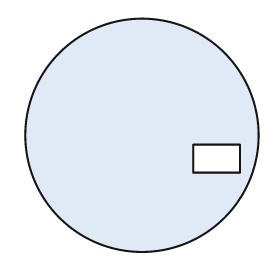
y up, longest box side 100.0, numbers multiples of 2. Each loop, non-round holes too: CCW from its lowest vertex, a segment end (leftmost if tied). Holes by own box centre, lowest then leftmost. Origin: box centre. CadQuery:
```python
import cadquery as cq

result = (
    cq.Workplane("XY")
    .moveTo(0.0, 0.0)
    .circle(50.0)
    .moveTo(22.0, -16.0)
    .lineTo(42.0, -16.0)
    .lineTo(42.0, -4.0)
    .lineTo(22.0, -4.0)
    .close()
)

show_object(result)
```